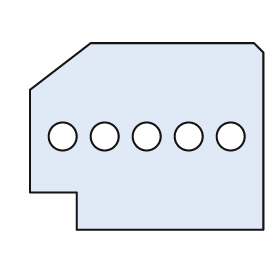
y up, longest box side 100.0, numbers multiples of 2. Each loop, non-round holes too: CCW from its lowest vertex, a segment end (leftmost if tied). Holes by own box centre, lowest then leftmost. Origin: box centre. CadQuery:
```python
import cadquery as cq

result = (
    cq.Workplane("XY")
    .moveTo(-30.0, -40.0)
    .lineTo(50.0, -40.0)
    .lineTo(50.0, 36.0)
    .lineTo(46.0, 40.0)
    .lineTo(-24.0, 40.0)
    .lineTo(-50.0, 20.0)
    .lineTo(-50.0, -24.0)
    .lineTo(-30.0, -24.0)
    .close()
    .moveTo(-36.0, 0.0)
    .circle(6.0)
    .moveTo(-18.0, 0.0)
    .circle(6.0)
    .moveTo(0.0, 0.0)
    .circle(6.0)
    .moveTo(18.0, 0.0)
    .circle(6.0)
    .moveTo(36.0, 0.0)
    .circle(6.0)
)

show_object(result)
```